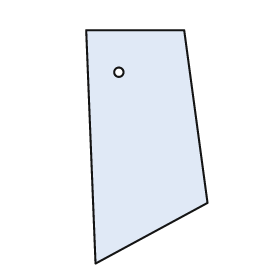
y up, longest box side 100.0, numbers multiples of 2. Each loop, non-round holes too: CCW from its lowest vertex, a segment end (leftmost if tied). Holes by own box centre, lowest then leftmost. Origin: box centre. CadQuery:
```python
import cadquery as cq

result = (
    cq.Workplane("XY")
    .moveTo(-22.0, -50.0)
    .lineTo(26.0, -24.0)
    .lineTo(16.0, 50.0)
    .lineTo(-26.0, 50.0)
    .close()
    .moveTo(-12.0, 32.0)
    .circle(2.0)
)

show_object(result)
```